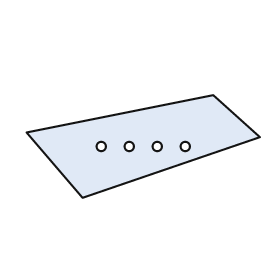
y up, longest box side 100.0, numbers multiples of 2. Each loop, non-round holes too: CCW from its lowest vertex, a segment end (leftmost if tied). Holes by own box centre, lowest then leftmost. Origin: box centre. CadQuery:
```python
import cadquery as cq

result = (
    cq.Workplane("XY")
    .moveTo(-26.0, -22.0)
    .lineTo(50.0, 4.0)
    .lineTo(30.0, 22.0)
    .lineTo(-50.0, 6.0)
    .close()
    .moveTo(-18.0, 0.0)
    .circle(2.0)
    .moveTo(-6.0, 0.0)
    .circle(2.0)
    .moveTo(6.0, 0.0)
    .circle(2.0)
    .moveTo(18.0, 0.0)
    .circle(2.0)
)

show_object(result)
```